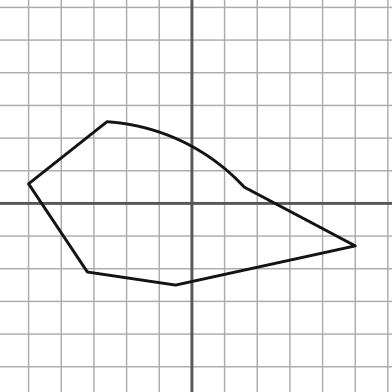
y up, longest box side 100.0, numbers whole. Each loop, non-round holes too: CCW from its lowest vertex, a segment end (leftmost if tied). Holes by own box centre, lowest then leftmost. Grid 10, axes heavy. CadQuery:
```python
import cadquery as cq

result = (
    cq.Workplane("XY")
    .moveTo(-5.0, -25.0)
    .lineTo(50.0, -13.0)
    .lineTo(16.0, 5.0)
    .threePointArc((-3.0, 19.0), (-26.0, 25.0))
    .lineTo(-50.0, 6.0)
    .lineTo(-32.0, -21.0)
    .close()
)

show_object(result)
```